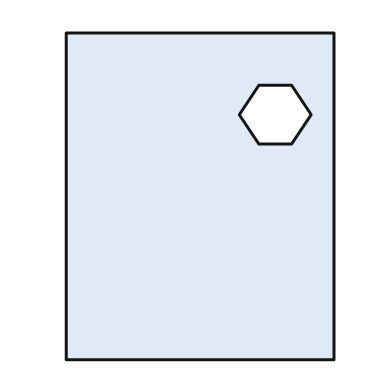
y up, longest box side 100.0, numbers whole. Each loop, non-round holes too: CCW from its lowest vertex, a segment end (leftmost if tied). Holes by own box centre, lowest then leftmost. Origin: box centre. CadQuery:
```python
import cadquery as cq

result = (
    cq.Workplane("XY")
    .moveTo(-41.0, -50.0)
    .lineTo(41.0, -50.0)
    .lineTo(41.0, 50.0)
    .lineTo(-41.0, 50.0)
    .close()
    .moveTo(18.0, 16.0)
    .lineTo(28.0, 16.0)
    .lineTo(34.0, 25.0)
    .lineTo(28.0, 34.0)
    .lineTo(18.0, 34.0)
    .lineTo(12.0, 25.0)
    .close()
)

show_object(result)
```